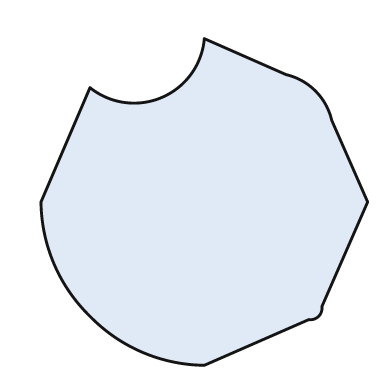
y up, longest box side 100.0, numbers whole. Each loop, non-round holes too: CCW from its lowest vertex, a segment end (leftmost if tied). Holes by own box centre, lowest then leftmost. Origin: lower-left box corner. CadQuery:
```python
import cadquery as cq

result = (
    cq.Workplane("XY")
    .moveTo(50.0, 0.0)
    .lineTo(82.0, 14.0)
    .threePointArc((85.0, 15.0), (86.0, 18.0))
    .lineTo(100.0, 50.0)
    .lineTo(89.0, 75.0)
    .threePointArc((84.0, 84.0), (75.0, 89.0))
    .lineTo(50.0, 100.0)
    .threePointArc((37.0, 82.0), (15.0, 85.0))
    .lineTo(0.0, 50.0)
    .threePointArc((4.0, 31.0), (15.0, 15.0))
    .threePointArc((31.0, 4.0), (50.0, 0.0))
    .close()
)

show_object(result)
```